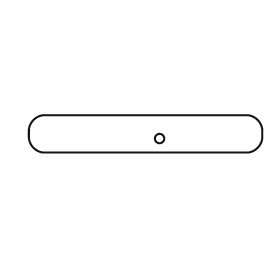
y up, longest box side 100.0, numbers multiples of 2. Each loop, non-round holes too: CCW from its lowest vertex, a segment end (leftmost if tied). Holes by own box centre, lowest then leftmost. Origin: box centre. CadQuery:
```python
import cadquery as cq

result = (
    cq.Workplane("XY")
    .moveTo(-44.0, -8.0)
    .lineTo(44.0, -8.0)
    .threePointArc((48.0, -6.0), (50.0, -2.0))
    .lineTo(50.0, 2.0)
    .threePointArc((48.0, 6.0), (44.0, 8.0))
    .lineTo(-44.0, 8.0)
    .threePointArc((-48.0, 6.0), (-50.0, 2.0))
    .lineTo(-50.0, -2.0)
    .threePointArc((-48.0, -6.0), (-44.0, -8.0))
    .close()
    .moveTo(6.0, -2.0)
    .circle(2.0)
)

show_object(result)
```